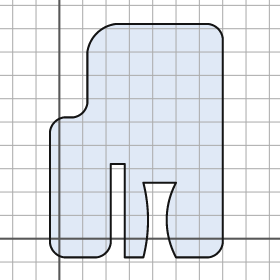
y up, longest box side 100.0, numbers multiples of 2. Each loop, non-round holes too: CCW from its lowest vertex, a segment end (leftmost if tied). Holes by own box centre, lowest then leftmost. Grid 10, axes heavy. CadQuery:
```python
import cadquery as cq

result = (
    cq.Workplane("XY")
    .moveTo(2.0, -8.0)
    .lineTo(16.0, -8.0)
    .threePointArc((20.0, -6.0), (22.0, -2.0))
    .lineTo(22.0, 32.0)
    .lineTo(28.0, 32.0)
    .lineTo(28.0, -8.0)
    .lineTo(36.0, -8.0)
    .threePointArc((38.0, 8.0), (36.0, 24.0))
    .lineTo(50.0, 24.0)
    .threePointArc((46.0, 8.0), (50.0, -8.0))
    .lineTo(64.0, -8.0)
    .threePointArc((68.0, -6.0), (70.0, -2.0))
    .lineTo(70.0, 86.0)
    .threePointArc((68.0, 90.0), (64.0, 92.0))
    .lineTo(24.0, 92.0)
    .threePointArc((16.0, 88.0), (12.0, 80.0))
    .lineTo(12.0, 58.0)
    .threePointArc((10.0, 54.0), (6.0, 52.0))
    .lineTo(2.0, 52.0)
    .threePointArc((-2.0, 50.0), (-4.0, 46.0))
    .lineTo(-4.0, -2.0)
    .threePointArc((-2.0, -6.0), (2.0, -8.0))
    .close()
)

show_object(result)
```